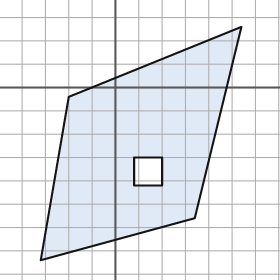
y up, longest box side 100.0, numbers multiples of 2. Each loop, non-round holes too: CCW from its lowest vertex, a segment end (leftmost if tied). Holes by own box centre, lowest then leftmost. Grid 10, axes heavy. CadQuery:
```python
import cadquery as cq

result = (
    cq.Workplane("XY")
    .moveTo(-32.0, -74.0)
    .lineTo(34.0, -56.0)
    .lineTo(54.0, 26.0)
    .lineTo(-20.0, -4.0)
    .close()
    .moveTo(8.0, -42.0)
    .lineTo(20.0, -42.0)
    .lineTo(20.0, -30.0)
    .lineTo(8.0, -30.0)
    .close()
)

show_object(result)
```